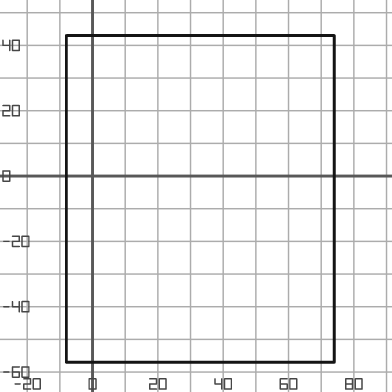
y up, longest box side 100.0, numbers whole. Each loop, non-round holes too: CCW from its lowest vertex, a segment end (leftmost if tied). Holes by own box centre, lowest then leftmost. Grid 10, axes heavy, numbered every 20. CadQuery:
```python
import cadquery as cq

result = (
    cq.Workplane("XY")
    .moveTo(-8.0, -57.0)
    .lineTo(74.0, -57.0)
    .lineTo(74.0, 43.0)
    .lineTo(-8.0, 43.0)
    .close()
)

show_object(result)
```